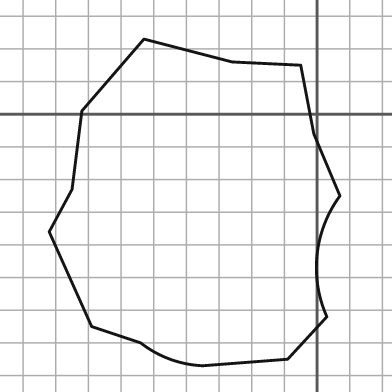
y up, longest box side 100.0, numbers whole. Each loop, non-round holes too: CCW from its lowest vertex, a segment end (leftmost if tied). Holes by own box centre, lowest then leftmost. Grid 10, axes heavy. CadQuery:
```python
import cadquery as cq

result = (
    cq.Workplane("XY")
    .moveTo(-35.0, -77.0)
    .lineTo(-9.0, -75.0)
    .lineTo(3.0, -62.0)
    .threePointArc((0.0, -43.0), (7.0, -25.0))
    .lineTo(-1.0, -6.0)
    .lineTo(-5.0, 15.0)
    .lineTo(-26.0, 16.0)
    .lineTo(-53.0, 23.0)
    .lineTo(-72.0, 1.0)
    .lineTo(-75.0, -23.0)
    .lineTo(-82.0, -36.0)
    .lineTo(-69.0, -65.0)
    .lineTo(-54.0, -70.0)
    .threePointArc((-45.0, -75.0), (-35.0, -77.0))
    .close()
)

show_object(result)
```